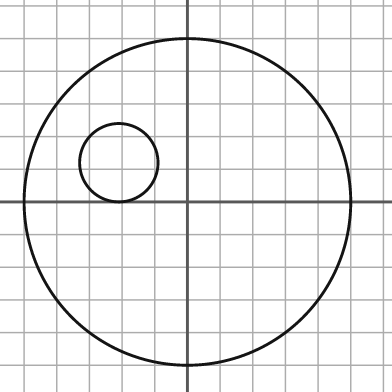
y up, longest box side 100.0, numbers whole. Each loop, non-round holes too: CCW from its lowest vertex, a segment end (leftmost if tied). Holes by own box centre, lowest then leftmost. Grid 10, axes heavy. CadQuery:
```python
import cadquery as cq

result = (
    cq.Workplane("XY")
    .moveTo(0.0, 0.0)
    .circle(50.0)
    .moveTo(-21.0, 12.0)
    .circle(12.0)
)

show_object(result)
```